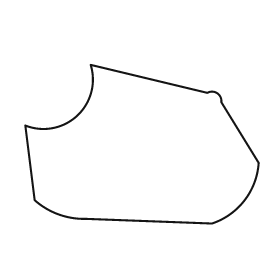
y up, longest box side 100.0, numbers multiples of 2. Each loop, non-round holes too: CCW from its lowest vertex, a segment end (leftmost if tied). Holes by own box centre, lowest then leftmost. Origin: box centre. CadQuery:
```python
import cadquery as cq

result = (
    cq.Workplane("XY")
    .moveTo(30.0, -34.0)
    .threePointArc((44.0, -24.0), (50.0, -8.0))
    .lineTo(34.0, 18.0)
    .threePointArc((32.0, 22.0), (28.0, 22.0))
    .lineTo(-22.0, 34.0)
    .threePointArc((-28.0, 12.0), (-50.0, 8.0))
    .lineTo(-46.0, -24.0)
    .threePointArc((-36.0, -30.0), (-24.0, -32.0))
    .close()
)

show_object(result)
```